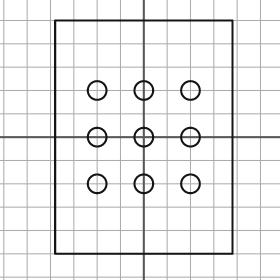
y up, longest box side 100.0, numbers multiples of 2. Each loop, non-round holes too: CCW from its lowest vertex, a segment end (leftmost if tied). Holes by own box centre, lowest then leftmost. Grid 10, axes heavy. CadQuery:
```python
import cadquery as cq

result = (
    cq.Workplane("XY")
    .moveTo(-38.0, -50.0)
    .lineTo(38.0, -50.0)
    .lineTo(38.0, 50.0)
    .lineTo(-38.0, 50.0)
    .close()
    .moveTo(-20.0, -20.0)
    .circle(4.0)
    .moveTo(0.0, -20.0)
    .circle(4.0)
    .moveTo(20.0, -20.0)
    .circle(4.0)
    .moveTo(-20.0, 0.0)
    .circle(4.0)
    .moveTo(0.0, 0.0)
    .circle(4.0)
    .moveTo(20.0, 0.0)
    .circle(4.0)
    .moveTo(-20.0, 20.0)
    .circle(4.0)
    .moveTo(0.0, 20.0)
    .circle(4.0)
    .moveTo(20.0, 20.0)
    .circle(4.0)
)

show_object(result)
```